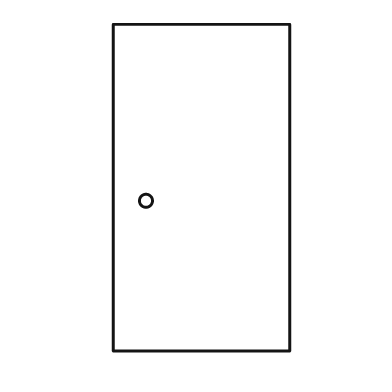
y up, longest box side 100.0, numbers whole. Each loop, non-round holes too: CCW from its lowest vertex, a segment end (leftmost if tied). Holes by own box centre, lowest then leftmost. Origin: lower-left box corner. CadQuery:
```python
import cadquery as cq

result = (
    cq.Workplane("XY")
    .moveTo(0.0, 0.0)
    .lineTo(54.0, 0.0)
    .lineTo(54.0, 100.0)
    .lineTo(0.0, 100.0)
    .close()
    .moveTo(10.0, 46.0)
    .circle(2.0)
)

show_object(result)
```